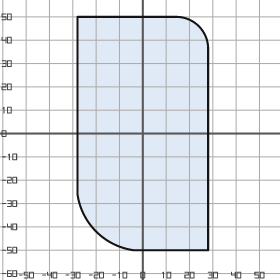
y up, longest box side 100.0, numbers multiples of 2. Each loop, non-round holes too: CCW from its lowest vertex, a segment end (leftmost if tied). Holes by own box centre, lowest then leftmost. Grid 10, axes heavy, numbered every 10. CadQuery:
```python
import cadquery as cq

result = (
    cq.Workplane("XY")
    .moveTo(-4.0, -50.0)
    .lineTo(28.0, -50.0)
    .lineTo(28.0, 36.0)
    .threePointArc((24.0, 46.0), (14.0, 50.0))
    .lineTo(-28.0, 50.0)
    .lineTo(-28.0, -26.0)
    .threePointArc((-20.0, -42.0), (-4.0, -50.0))
    .close()
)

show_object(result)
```